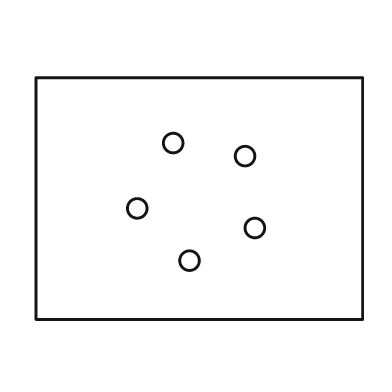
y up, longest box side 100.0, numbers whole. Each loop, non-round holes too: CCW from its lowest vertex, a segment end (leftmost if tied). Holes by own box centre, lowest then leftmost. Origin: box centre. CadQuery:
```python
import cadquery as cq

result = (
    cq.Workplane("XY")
    .moveTo(-50.0, -37.0)
    .lineTo(50.0, -37.0)
    .lineTo(50.0, 37.0)
    .lineTo(-50.0, 37.0)
    .close()
    .moveTo(-3.0, -19.0)
    .circle(3.0)
    .moveTo(17.0, -9.0)
    .circle(3.0)
    .moveTo(-19.0, -3.0)
    .circle(3.0)
    .moveTo(14.0, 13.0)
    .circle(3.0)
    .moveTo(-8.0, 17.0)
    .circle(3.0)
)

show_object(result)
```